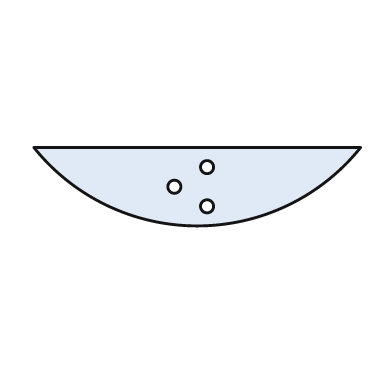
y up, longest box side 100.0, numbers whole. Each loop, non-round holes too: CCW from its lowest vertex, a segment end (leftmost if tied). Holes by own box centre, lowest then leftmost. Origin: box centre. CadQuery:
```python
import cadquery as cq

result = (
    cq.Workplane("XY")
    .moveTo(-50.0, 12.0)
    .threePointArc((0.0, -12.0), (50.0, 12.0))
    .close()
    .moveTo(3.0, -6.0)
    .circle(2.0)
    .moveTo(-7.0, 0.0)
    .circle(2.0)
    .moveTo(3.0, 6.0)
    .circle(2.0)
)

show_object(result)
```